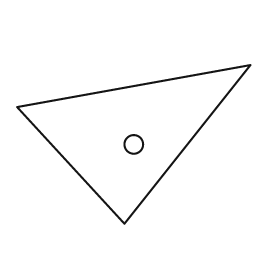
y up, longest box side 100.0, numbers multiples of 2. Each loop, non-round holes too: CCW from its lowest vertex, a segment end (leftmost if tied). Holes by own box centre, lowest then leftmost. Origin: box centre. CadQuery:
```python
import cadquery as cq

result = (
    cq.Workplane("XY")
    .moveTo(-4.0, -34.0)
    .lineTo(50.0, 34.0)
    .lineTo(-50.0, 16.0)
    .close()
    .moveTo(0.0, 0.0)
    .circle(4.0)
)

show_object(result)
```